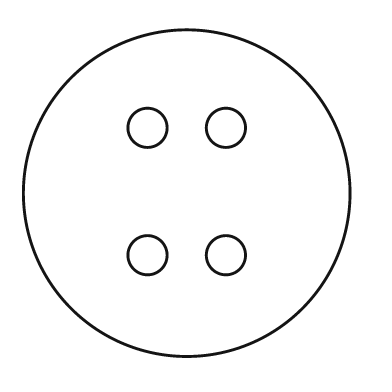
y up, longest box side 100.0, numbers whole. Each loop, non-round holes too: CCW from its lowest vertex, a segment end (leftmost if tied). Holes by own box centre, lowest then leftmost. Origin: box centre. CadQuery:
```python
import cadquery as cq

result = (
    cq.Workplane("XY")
    .moveTo(0.0, 0.0)
    .circle(50.0)
    .moveTo(-12.0, -19.0)
    .circle(6.0)
    .moveTo(12.0, -19.0)
    .circle(6.0)
    .moveTo(-12.0, 20.0)
    .circle(6.0)
    .moveTo(12.0, 20.0)
    .circle(6.0)
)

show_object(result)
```